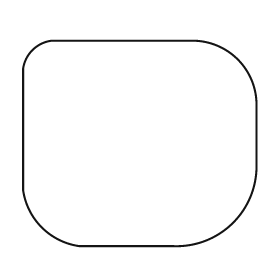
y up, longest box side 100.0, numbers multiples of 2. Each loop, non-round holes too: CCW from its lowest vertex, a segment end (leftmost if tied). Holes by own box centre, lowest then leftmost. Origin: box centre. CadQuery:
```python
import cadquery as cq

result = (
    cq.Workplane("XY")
    .moveTo(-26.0, -44.0)
    .lineTo(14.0, -44.0)
    .threePointArc((40.0, -34.0), (50.0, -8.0))
    .lineTo(50.0, 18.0)
    .threePointArc((42.0, 36.0), (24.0, 44.0))
    .lineTo(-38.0, 44.0)
    .threePointArc((-46.0, 40.0), (-50.0, 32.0))
    .lineTo(-50.0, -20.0)
    .threePointArc((-42.0, -36.0), (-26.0, -44.0))
    .close()
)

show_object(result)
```